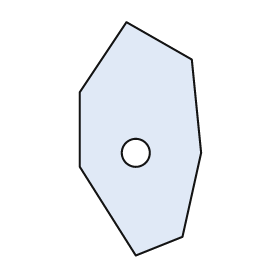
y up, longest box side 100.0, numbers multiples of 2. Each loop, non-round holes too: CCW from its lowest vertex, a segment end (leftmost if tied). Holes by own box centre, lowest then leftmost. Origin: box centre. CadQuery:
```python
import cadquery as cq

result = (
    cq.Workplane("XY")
    .moveTo(-2.0, -50.0)
    .lineTo(18.0, -42.0)
    .lineTo(26.0, -6.0)
    .lineTo(22.0, 34.0)
    .lineTo(-6.0, 50.0)
    .lineTo(-26.0, 20.0)
    .lineTo(-26.0, -12.0)
    .close()
    .moveTo(-2.0, -6.0)
    .circle(6.0)
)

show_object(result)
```